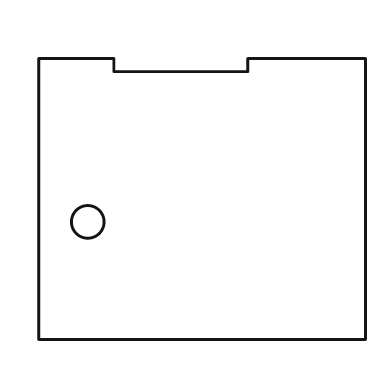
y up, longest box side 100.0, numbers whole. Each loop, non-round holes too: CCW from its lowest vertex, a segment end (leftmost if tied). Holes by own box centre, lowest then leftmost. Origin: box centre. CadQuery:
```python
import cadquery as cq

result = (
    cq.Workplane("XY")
    .moveTo(-50.0, -43.0)
    .lineTo(50.0, -43.0)
    .lineTo(50.0, 43.0)
    .lineTo(14.0, 43.0)
    .lineTo(14.0, 39.0)
    .lineTo(-27.0, 39.0)
    .lineTo(-27.0, 43.0)
    .lineTo(-50.0, 43.0)
    .close()
    .moveTo(-35.0, -7.0)
    .circle(5.0)
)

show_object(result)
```